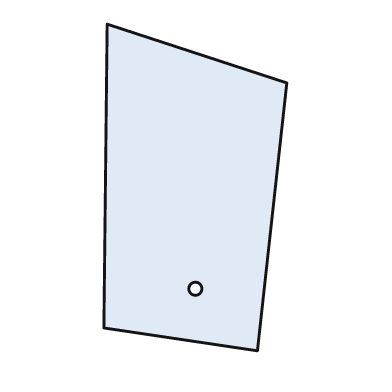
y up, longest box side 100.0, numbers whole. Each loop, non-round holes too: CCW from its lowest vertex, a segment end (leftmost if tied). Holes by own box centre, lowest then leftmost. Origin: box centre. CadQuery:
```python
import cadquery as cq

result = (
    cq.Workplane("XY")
    .moveTo(19.0, -50.0)
    .lineTo(28.0, 32.0)
    .lineTo(-27.0, 50.0)
    .lineTo(-28.0, -43.0)
    .close()
    .moveTo(0.0, -31.0)
    .circle(2.0)
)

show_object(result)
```